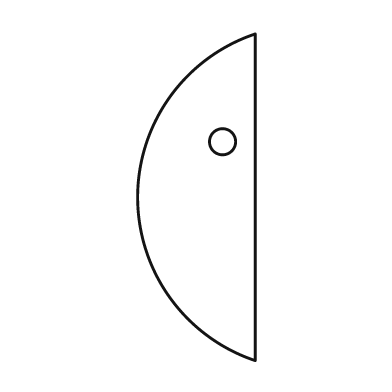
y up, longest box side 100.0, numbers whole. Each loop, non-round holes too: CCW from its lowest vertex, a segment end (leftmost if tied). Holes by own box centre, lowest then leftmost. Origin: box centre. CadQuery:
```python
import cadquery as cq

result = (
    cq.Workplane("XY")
    .moveTo(18.0, -50.0)
    .lineTo(18.0, 50.0)
    .threePointArc((-18.0, 0.0), (18.0, -50.0))
    .close()
    .moveTo(8.0, 17.0)
    .circle(4.0)
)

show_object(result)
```